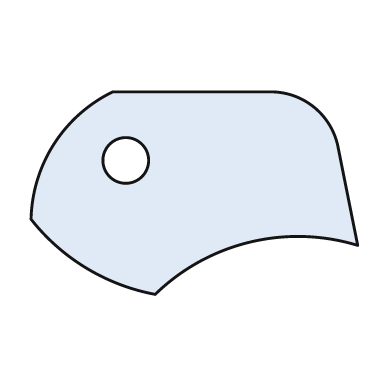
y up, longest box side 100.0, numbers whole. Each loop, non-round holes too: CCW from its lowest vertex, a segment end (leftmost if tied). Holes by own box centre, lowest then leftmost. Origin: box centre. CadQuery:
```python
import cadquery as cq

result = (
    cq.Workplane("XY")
    .moveTo(-12.0, -31.0)
    .threePointArc((17.0, -15.0), (50.0, -16.0))
    .lineTo(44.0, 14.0)
    .threePointArc((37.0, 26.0), (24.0, 31.0))
    .lineTo(-25.0, 31.0)
    .threePointArc((-43.0, 15.0), (-50.0, -8.0))
    .threePointArc((-33.0, -23.0), (-12.0, -31.0))
    .close()
    .moveTo(-21.0, 10.0)
    .circle(7.0)
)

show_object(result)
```